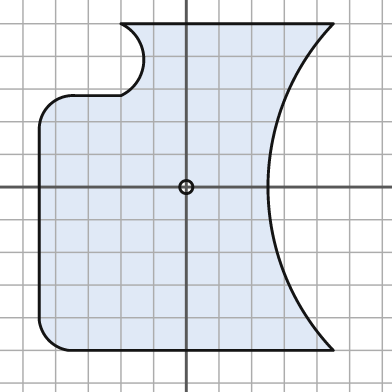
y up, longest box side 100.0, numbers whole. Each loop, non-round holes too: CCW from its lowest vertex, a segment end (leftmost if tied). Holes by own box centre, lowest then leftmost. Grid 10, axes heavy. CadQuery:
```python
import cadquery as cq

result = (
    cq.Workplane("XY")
    .moveTo(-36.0, -50.0)
    .lineTo(45.0, -50.0)
    .threePointArc((25.0, 0.0), (45.0, 50.0))
    .lineTo(-20.0, 50.0)
    .threePointArc((-13.0, 39.0), (-20.0, 28.0))
    .lineTo(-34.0, 28.0)
    .threePointArc((-42.0, 25.0), (-45.0, 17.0))
    .lineTo(-45.0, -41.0)
    .threePointArc((-42.0, -47.0), (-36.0, -50.0))
    .close()
    .moveTo(0.0, 0.0)
    .circle(2.0)
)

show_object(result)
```